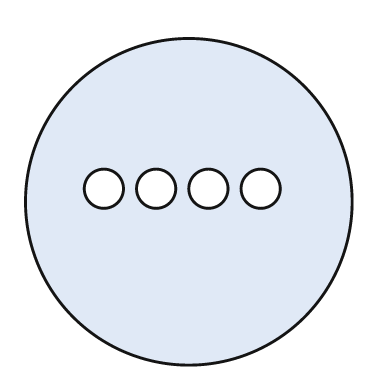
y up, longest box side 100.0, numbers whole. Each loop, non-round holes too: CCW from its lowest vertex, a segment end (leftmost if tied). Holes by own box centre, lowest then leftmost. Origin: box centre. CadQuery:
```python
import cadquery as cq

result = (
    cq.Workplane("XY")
    .moveTo(0.0, 0.0)
    .circle(50.0)
    .moveTo(-26.0, 4.0)
    .circle(6.0)
    .moveTo(-10.0, 4.0)
    .circle(6.0)
    .moveTo(6.0, 4.0)
    .circle(6.0)
    .moveTo(22.0, 4.0)
    .circle(6.0)
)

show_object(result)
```